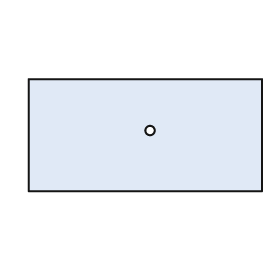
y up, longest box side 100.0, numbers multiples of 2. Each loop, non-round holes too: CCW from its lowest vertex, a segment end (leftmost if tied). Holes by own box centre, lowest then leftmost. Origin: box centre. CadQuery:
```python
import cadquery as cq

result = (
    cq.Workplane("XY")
    .moveTo(-50.0, -24.0)
    .lineTo(50.0, -24.0)
    .lineTo(50.0, 24.0)
    .lineTo(-50.0, 24.0)
    .close()
    .moveTo(2.0, 2.0)
    .circle(2.0)
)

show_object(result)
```